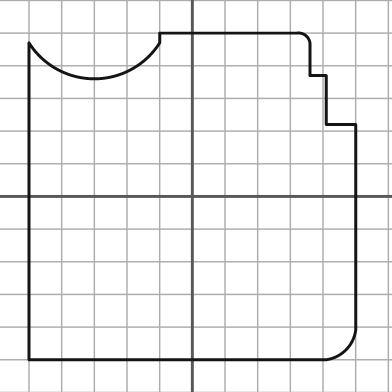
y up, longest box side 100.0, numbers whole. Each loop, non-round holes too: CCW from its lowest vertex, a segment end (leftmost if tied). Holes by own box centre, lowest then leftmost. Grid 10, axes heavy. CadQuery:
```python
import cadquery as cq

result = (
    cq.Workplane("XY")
    .moveTo(-50.0, -50.0)
    .lineTo(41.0, -50.0)
    .threePointArc((47.0, -47.0), (50.0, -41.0))
    .lineTo(50.0, 22.0)
    .lineTo(41.0, 22.0)
    .lineTo(41.0, 37.0)
    .lineTo(36.0, 37.0)
    .lineTo(36.0, 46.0)
    .threePointArc((35.0, 49.0), (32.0, 50.0))
    .lineTo(-10.0, 50.0)
    .lineTo(-10.0, 47.0)
    .threePointArc((-30.0, 36.0), (-50.0, 47.0))
    .close()
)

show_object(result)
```